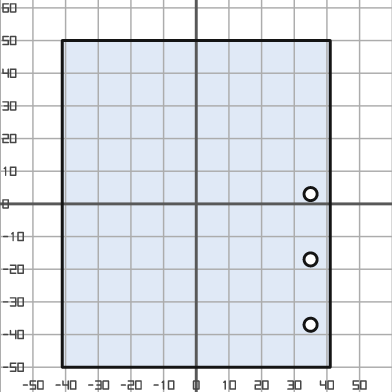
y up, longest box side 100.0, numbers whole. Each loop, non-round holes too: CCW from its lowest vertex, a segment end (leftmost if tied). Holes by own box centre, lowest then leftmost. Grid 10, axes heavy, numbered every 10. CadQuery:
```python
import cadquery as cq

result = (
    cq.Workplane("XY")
    .moveTo(-41.0, -50.0)
    .lineTo(41.0, -50.0)
    .lineTo(41.0, 50.0)
    .lineTo(-41.0, 50.0)
    .close()
    .moveTo(35.0, -37.0)
    .circle(2.0)
    .moveTo(35.0, -17.0)
    .circle(2.0)
    .moveTo(35.0, 3.0)
    .circle(2.0)
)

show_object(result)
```